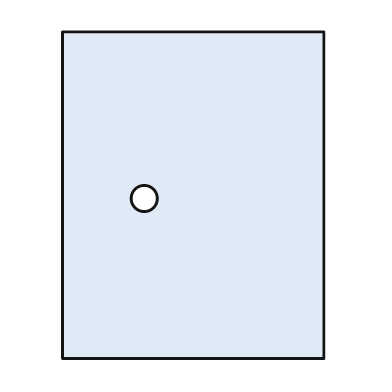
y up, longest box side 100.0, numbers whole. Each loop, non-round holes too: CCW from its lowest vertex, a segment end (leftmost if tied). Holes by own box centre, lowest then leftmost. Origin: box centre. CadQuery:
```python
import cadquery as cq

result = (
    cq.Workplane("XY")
    .moveTo(-40.0, -50.0)
    .lineTo(40.0, -50.0)
    .lineTo(40.0, 50.0)
    .lineTo(-40.0, 50.0)
    .close()
    .moveTo(-15.0, -1.0)
    .circle(4.0)
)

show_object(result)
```